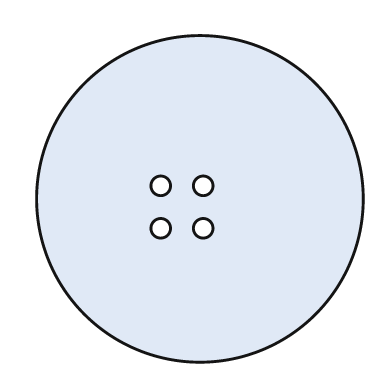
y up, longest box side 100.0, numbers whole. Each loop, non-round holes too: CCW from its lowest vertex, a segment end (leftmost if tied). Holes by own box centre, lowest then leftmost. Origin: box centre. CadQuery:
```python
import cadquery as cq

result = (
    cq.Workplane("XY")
    .moveTo(0.0, 0.0)
    .circle(50.0)
    .moveTo(-12.0, -9.0)
    .circle(3.0)
    .moveTo(1.0, -9.0)
    .circle(3.0)
    .moveTo(-12.0, 4.0)
    .circle(3.0)
    .moveTo(1.0, 4.0)
    .circle(3.0)
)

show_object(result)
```